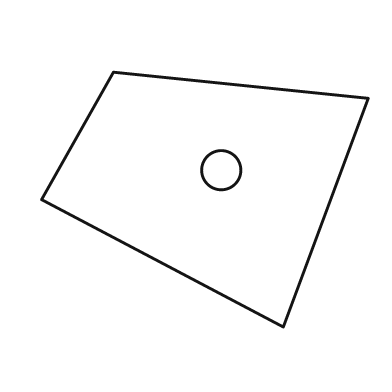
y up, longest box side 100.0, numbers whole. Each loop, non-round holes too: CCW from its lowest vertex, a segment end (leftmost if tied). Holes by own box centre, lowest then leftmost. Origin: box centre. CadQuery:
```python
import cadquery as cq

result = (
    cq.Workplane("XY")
    .moveTo(24.0, -39.0)
    .lineTo(50.0, 31.0)
    .lineTo(-28.0, 39.0)
    .lineTo(-50.0, 0.0)
    .close()
    .moveTo(5.0, 9.0)
    .circle(6.0)
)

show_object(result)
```